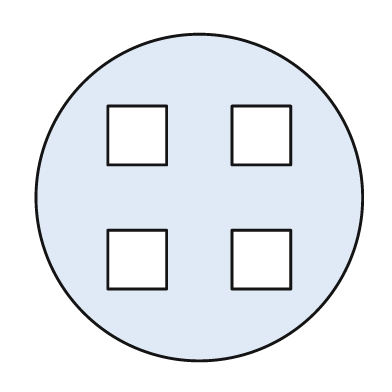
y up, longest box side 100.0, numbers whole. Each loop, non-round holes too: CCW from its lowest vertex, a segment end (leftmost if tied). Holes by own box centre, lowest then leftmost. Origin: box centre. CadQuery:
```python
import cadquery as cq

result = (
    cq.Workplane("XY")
    .moveTo(0.0, 0.0)
    .circle(50.0)
    .moveTo(-28.0, -28.0)
    .lineTo(-10.0, -28.0)
    .lineTo(-10.0, -10.0)
    .lineTo(-28.0, -10.0)
    .close()
    .moveTo(10.0, -28.0)
    .lineTo(28.0, -28.0)
    .lineTo(28.0, -10.0)
    .lineTo(10.0, -10.0)
    .close()
    .moveTo(-28.0, 10.0)
    .lineTo(-10.0, 10.0)
    .lineTo(-10.0, 28.0)
    .lineTo(-28.0, 28.0)
    .close()
    .moveTo(10.0, 10.0)
    .lineTo(28.0, 10.0)
    .lineTo(28.0, 28.0)
    .lineTo(10.0, 28.0)
    .close()
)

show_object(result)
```